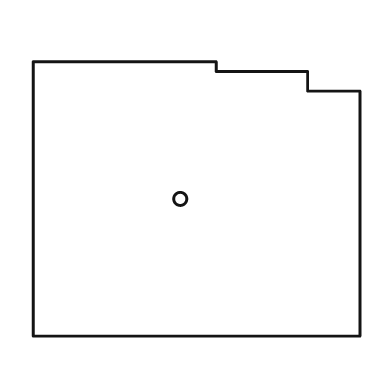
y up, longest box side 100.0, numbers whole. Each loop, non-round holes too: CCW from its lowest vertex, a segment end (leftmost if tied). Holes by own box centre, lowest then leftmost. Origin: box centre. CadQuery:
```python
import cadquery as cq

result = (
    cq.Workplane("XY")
    .moveTo(-50.0, -42.0)
    .lineTo(50.0, -42.0)
    .lineTo(50.0, 33.0)
    .lineTo(34.0, 33.0)
    .lineTo(34.0, 39.0)
    .lineTo(6.0, 39.0)
    .lineTo(6.0, 42.0)
    .lineTo(-50.0, 42.0)
    .close()
    .moveTo(-5.0, 0.0)
    .circle(2.0)
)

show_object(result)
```